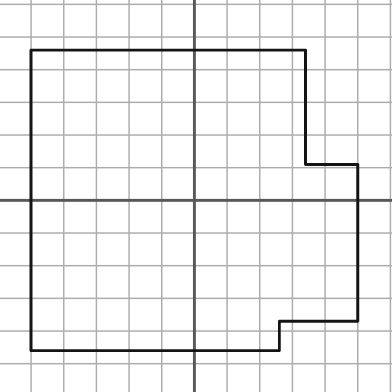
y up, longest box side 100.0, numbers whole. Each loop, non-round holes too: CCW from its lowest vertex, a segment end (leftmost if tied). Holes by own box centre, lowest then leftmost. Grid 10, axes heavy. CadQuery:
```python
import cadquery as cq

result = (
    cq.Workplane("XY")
    .moveTo(-50.0, -46.0)
    .lineTo(26.0, -46.0)
    .lineTo(26.0, -37.0)
    .lineTo(50.0, -37.0)
    .lineTo(50.0, 11.0)
    .lineTo(34.0, 11.0)
    .lineTo(34.0, 46.0)
    .lineTo(-50.0, 46.0)
    .close()
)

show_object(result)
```